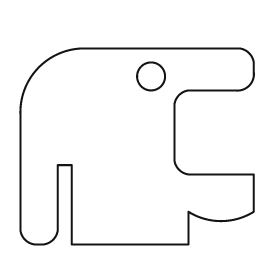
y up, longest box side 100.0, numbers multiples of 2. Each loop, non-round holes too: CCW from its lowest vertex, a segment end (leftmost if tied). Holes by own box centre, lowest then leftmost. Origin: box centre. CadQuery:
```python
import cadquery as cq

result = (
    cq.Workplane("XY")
    .moveTo(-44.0, -42.0)
    .lineTo(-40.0, -42.0)
    .threePointArc((-36.0, -40.0), (-34.0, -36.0))
    .lineTo(-34.0, -8.0)
    .lineTo(-28.0, -8.0)
    .lineTo(-28.0, -42.0)
    .lineTo(22.0, -42.0)
    .lineTo(22.0, -28.0)
    .threePointArc((36.0, -32.0), (50.0, -28.0))
    .lineTo(50.0, -12.0)
    .lineTo(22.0, -12.0)
    .threePointArc((18.0, -10.0), (16.0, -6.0))
    .lineTo(16.0, 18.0)
    .threePointArc((18.0, 22.0), (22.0, 24.0))
    .lineTo(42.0, 24.0)
    .threePointArc((48.0, 26.0), (50.0, 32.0))
    .lineTo(50.0, 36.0)
    .threePointArc((48.0, 40.0), (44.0, 42.0))
    .lineTo(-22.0, 42.0)
    .threePointArc((-42.0, 34.0), (-50.0, 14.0))
    .lineTo(-50.0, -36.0)
    .threePointArc((-48.0, -40.0), (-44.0, -42.0))
    .close()
    .moveTo(6.0, 30.0)
    .circle(6.0)
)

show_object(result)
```